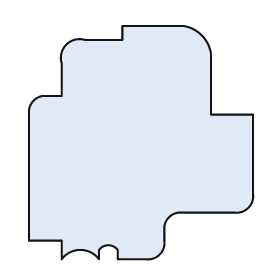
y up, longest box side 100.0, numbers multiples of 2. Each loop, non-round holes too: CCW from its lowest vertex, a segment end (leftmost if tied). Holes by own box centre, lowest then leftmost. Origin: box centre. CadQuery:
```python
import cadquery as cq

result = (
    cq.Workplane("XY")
    .moveTo(-34.0, -50.0)
    .threePointArc((-26.0, -46.0), (-18.0, -50.0))
    .lineTo(-18.0, -46.0)
    .threePointArc((-14.0, -44.0), (-10.0, -46.0))
    .lineTo(-10.0, -50.0)
    .lineTo(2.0, -50.0)
    .threePointArc((8.0, -48.0), (10.0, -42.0))
    .lineTo(10.0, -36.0)
    .threePointArc((12.0, -32.0), (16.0, -30.0))
    .lineTo(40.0, -30.0)
    .threePointArc((46.0, -28.0), (48.0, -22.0))
    .lineTo(48.0, 12.0)
    .lineTo(30.0, 12.0)
    .lineTo(30.0, 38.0)
    .threePointArc((26.0, 46.0), (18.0, 50.0))
    .lineTo(-8.0, 50.0)
    .lineTo(-8.0, 44.0)
    .lineTo(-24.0, 44.0)
    .threePointArc((-32.0, 42.0), (-34.0, 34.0))
    .lineTo(-34.0, 20.0)
    .lineTo(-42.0, 20.0)
    .threePointArc((-46.0, 18.0), (-48.0, 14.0))
    .lineTo(-48.0, -42.0)
    .lineTo(-34.0, -42.0)
    .close()
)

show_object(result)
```